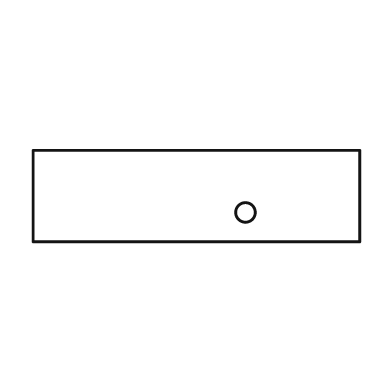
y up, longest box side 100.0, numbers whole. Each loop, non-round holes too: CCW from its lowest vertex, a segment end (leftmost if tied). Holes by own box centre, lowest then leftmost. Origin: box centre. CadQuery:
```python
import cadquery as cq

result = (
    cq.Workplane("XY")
    .moveTo(-50.0, -14.0)
    .lineTo(50.0, -14.0)
    .lineTo(50.0, 14.0)
    .lineTo(-50.0, 14.0)
    .close()
    .moveTo(15.0, -5.0)
    .circle(3.0)
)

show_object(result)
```